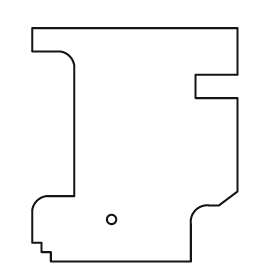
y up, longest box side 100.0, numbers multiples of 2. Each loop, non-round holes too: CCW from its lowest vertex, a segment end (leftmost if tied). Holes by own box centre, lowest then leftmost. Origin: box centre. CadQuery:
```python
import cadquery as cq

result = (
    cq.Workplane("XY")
    .moveTo(-36.0, -50.0)
    .lineTo(24.0, -50.0)
    .lineTo(24.0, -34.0)
    .threePointArc((26.0, -28.0), (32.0, -26.0))
    .lineTo(36.0, -26.0)
    .lineTo(44.0, -20.0)
    .lineTo(44.0, 20.0)
    .lineTo(26.0, 20.0)
    .lineTo(26.0, 30.0)
    .lineTo(44.0, 30.0)
    .lineTo(44.0, 50.0)
    .lineTo(-44.0, 50.0)
    .lineTo(-44.0, 40.0)
    .lineTo(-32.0, 40.0)
    .threePointArc((-28.0, 38.0), (-26.0, 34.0))
    .lineTo(-26.0, -22.0)
    .lineTo(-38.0, -22.0)
    .threePointArc((-42.0, -24.0), (-44.0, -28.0))
    .lineTo(-44.0, -42.0)
    .lineTo(-40.0, -42.0)
    .lineTo(-40.0, -46.0)
    .lineTo(-36.0, -46.0)
    .close()
    .moveTo(-10.0, -32.0)
    .circle(2.0)
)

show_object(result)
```